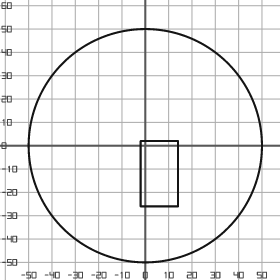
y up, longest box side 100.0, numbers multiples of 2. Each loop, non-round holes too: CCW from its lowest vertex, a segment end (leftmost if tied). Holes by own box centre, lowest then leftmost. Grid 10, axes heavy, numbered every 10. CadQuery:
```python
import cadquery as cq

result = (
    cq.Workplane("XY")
    .moveTo(0.0, 0.0)
    .circle(50.0)
    .moveTo(-2.0, -26.0)
    .lineTo(14.0, -26.0)
    .lineTo(14.0, 2.0)
    .lineTo(-2.0, 2.0)
    .close()
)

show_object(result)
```